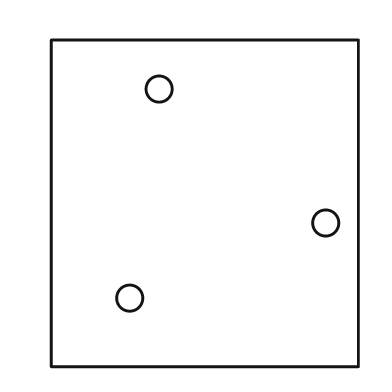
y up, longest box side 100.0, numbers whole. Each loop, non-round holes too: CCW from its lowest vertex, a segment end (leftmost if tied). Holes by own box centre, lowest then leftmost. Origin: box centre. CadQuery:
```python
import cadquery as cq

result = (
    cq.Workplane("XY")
    .moveTo(-47.0, -50.0)
    .lineTo(47.0, -50.0)
    .lineTo(47.0, 50.0)
    .lineTo(-47.0, 50.0)
    .close()
    .moveTo(-23.0, -29.0)
    .circle(4.0)
    .moveTo(37.0, -6.0)
    .circle(4.0)
    .moveTo(-14.0, 35.0)
    .circle(4.0)
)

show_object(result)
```